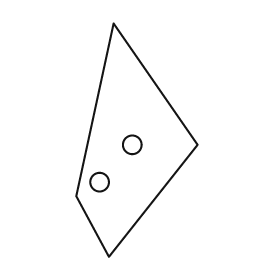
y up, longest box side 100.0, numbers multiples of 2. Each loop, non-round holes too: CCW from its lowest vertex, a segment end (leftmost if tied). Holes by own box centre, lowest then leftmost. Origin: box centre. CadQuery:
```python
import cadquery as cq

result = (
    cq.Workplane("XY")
    .moveTo(-12.0, -50.0)
    .lineTo(26.0, -2.0)
    .lineTo(-10.0, 50.0)
    .lineTo(-26.0, -24.0)
    .close()
    .moveTo(-16.0, -18.0)
    .circle(4.0)
    .moveTo(-2.0, -2.0)
    .circle(4.0)
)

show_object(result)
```